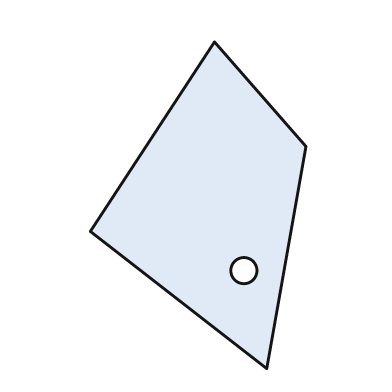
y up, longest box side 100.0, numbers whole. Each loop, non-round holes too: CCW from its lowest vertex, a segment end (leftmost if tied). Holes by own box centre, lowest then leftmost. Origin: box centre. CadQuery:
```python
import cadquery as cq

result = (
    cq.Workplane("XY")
    .moveTo(21.0, -50.0)
    .lineTo(33.0, 18.0)
    .lineTo(5.0, 50.0)
    .lineTo(-33.0, -8.0)
    .close()
    .moveTo(14.0, -20.0)
    .circle(4.0)
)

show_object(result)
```